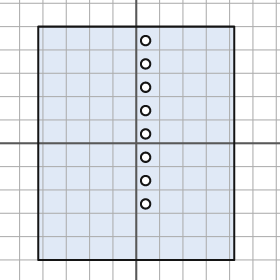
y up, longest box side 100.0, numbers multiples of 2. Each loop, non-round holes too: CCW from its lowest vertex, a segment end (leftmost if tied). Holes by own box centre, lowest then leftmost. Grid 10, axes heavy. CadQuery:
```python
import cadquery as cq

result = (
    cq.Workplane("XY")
    .moveTo(-42.0, -50.0)
    .lineTo(42.0, -50.0)
    .lineTo(42.0, 50.0)
    .lineTo(-42.0, 50.0)
    .close()
    .moveTo(4.0, -26.0)
    .circle(2.0)
    .moveTo(4.0, -16.0)
    .circle(2.0)
    .moveTo(4.0, -6.0)
    .circle(2.0)
    .moveTo(4.0, 4.0)
    .circle(2.0)
    .moveTo(4.0, 14.0)
    .circle(2.0)
    .moveTo(4.0, 24.0)
    .circle(2.0)
    .moveTo(4.0, 34.0)
    .circle(2.0)
    .moveTo(4.0, 44.0)
    .circle(2.0)
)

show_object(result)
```